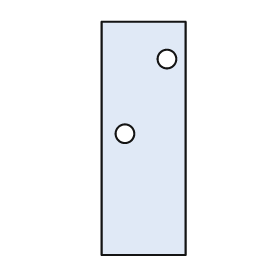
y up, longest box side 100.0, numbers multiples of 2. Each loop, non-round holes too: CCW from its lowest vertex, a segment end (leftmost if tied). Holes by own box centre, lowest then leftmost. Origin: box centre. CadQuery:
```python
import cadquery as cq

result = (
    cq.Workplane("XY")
    .moveTo(-18.0, -50.0)
    .lineTo(18.0, -50.0)
    .lineTo(18.0, 50.0)
    .lineTo(-18.0, 50.0)
    .close()
    .moveTo(-8.0, 2.0)
    .circle(4.0)
    .moveTo(10.0, 34.0)
    .circle(4.0)
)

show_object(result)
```